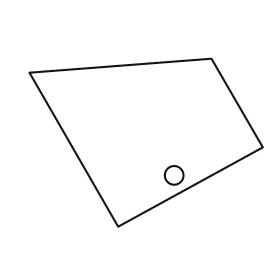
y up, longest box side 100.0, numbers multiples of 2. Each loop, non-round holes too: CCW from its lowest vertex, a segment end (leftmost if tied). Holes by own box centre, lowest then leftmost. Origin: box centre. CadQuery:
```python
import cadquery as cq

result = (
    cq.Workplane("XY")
    .moveTo(-12.0, -36.0)
    .lineTo(50.0, -2.0)
    .lineTo(28.0, 36.0)
    .lineTo(-50.0, 30.0)
    .close()
    .moveTo(12.0, -14.0)
    .circle(4.0)
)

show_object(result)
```